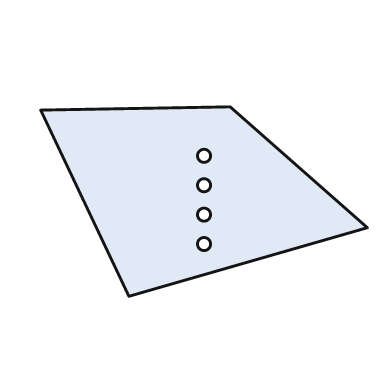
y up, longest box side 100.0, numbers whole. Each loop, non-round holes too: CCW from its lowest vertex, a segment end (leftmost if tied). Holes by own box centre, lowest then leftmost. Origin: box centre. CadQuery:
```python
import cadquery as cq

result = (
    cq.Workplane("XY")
    .moveTo(-23.0, -29.0)
    .lineTo(50.0, -8.0)
    .lineTo(8.0, 29.0)
    .lineTo(-50.0, 28.0)
    .close()
    .moveTo(0.0, -13.0)
    .circle(2.0)
    .moveTo(0.0, -4.0)
    .circle(2.0)
    .moveTo(0.0, 5.0)
    .circle(2.0)
    .moveTo(0.0, 14.0)
    .circle(2.0)
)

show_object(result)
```